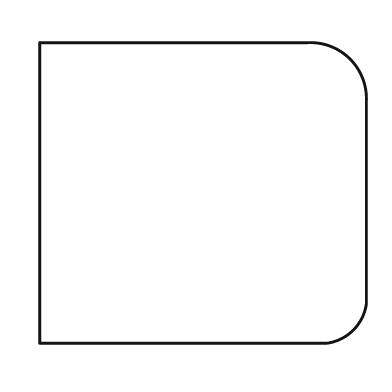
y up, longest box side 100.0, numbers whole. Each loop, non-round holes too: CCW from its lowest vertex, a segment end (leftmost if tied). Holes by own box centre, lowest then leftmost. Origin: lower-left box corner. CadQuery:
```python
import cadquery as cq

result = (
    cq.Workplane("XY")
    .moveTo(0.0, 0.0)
    .lineTo(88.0, 0.0)
    .threePointArc((96.0, 4.0), (100.0, 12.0))
    .lineTo(100.0, 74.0)
    .threePointArc((95.0, 87.0), (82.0, 92.0))
    .lineTo(0.0, 92.0)
    .close()
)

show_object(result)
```